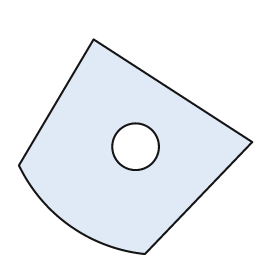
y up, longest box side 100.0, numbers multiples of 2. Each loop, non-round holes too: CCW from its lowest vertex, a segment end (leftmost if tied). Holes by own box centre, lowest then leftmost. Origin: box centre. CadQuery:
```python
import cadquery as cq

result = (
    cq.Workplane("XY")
    .moveTo(4.0, -46.0)
    .lineTo(50.0, 2.0)
    .lineTo(-18.0, 46.0)
    .lineTo(-50.0, -8.0)
    .threePointArc((-28.0, -34.0), (4.0, -46.0))
    .close()
    .moveTo(0.0, 0.0)
    .circle(10.0)
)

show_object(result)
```